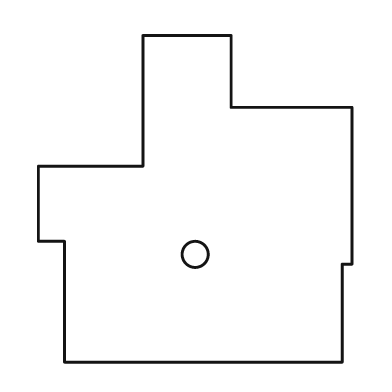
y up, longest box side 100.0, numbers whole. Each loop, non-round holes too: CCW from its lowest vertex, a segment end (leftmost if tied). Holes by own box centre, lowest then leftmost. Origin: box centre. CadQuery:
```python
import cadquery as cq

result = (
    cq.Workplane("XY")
    .moveTo(-40.0, -50.0)
    .lineTo(45.0, -50.0)
    .lineTo(45.0, -20.0)
    .lineTo(48.0, -20.0)
    .lineTo(48.0, 28.0)
    .lineTo(11.0, 28.0)
    .lineTo(11.0, 50.0)
    .lineTo(-16.0, 50.0)
    .lineTo(-16.0, 10.0)
    .lineTo(-48.0, 10.0)
    .lineTo(-48.0, -13.0)
    .lineTo(-40.0, -13.0)
    .close()
    .moveTo(0.0, -17.0)
    .circle(4.0)
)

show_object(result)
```